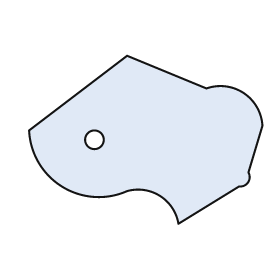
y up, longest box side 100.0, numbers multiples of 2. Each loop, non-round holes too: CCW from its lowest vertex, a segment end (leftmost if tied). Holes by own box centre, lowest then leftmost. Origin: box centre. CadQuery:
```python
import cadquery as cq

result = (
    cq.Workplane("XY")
    .moveTo(14.0, -36.0)
    .lineTo(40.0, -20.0)
    .threePointArc((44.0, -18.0), (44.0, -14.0))
    .lineTo(50.0, 6.0)
    .threePointArc((42.0, 20.0), (26.0, 22.0))
    .lineTo(-8.0, 36.0)
    .lineTo(-50.0, 4.0)
    .threePointArc((-36.0, -20.0), (-8.0, -22.0))
    .threePointArc((6.0, -24.0), (14.0, -36.0))
    .close()
    .moveTo(-22.0, 0.0)
    .circle(4.0)
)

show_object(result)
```